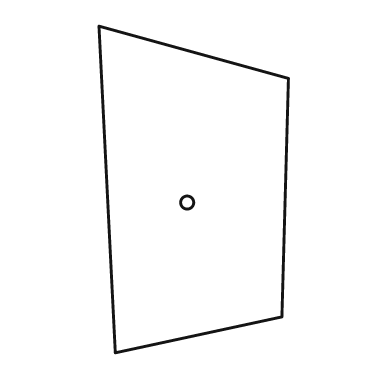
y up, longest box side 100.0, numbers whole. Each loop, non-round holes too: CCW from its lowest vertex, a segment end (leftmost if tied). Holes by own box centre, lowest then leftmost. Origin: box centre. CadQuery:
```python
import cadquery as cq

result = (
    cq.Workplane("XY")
    .moveTo(-24.0, -50.0)
    .lineTo(27.0, -39.0)
    .lineTo(29.0, 34.0)
    .lineTo(-29.0, 50.0)
    .close()
    .moveTo(-2.0, -4.0)
    .circle(2.0)
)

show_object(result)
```